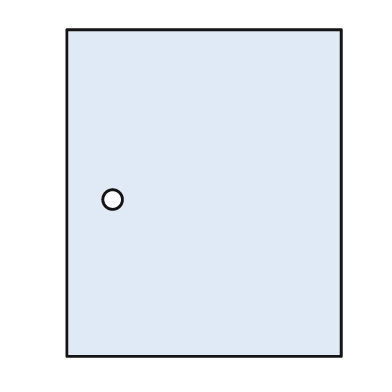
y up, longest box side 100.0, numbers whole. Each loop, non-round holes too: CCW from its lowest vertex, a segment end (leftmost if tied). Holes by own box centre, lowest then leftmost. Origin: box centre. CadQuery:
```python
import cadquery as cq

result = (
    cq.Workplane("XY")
    .moveTo(-42.0, -50.0)
    .lineTo(42.0, -50.0)
    .lineTo(42.0, 50.0)
    .lineTo(-42.0, 50.0)
    .close()
    .moveTo(-28.0, -2.0)
    .circle(3.0)
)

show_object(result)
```